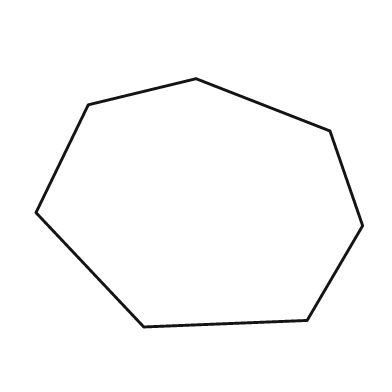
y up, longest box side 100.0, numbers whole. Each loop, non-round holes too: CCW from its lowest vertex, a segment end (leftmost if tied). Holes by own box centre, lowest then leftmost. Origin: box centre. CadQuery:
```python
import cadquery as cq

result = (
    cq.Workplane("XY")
    .moveTo(-17.0, -38.0)
    .lineTo(33.0, -36.0)
    .lineTo(50.0, -7.0)
    .lineTo(40.0, 22.0)
    .lineTo(-1.0, 38.0)
    .lineTo(-34.0, 30.0)
    .lineTo(-50.0, -3.0)
    .close()
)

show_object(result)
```